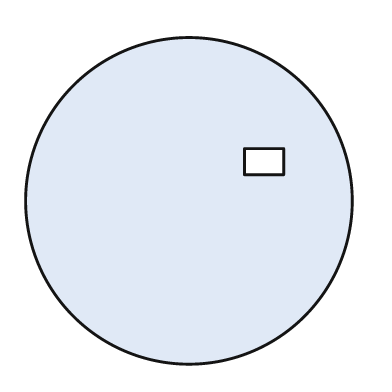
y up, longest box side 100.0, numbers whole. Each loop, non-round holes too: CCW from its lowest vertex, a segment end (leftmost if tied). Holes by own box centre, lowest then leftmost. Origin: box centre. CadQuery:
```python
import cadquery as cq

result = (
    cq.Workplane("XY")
    .moveTo(0.0, 0.0)
    .circle(50.0)
    .moveTo(17.0, 8.0)
    .lineTo(29.0, 8.0)
    .lineTo(29.0, 16.0)
    .lineTo(17.0, 16.0)
    .close()
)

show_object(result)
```